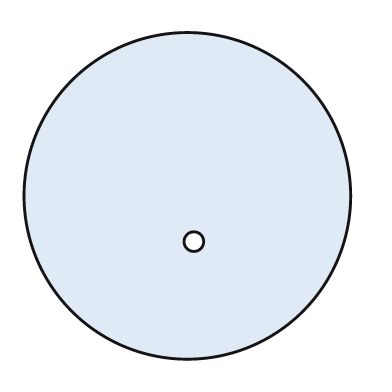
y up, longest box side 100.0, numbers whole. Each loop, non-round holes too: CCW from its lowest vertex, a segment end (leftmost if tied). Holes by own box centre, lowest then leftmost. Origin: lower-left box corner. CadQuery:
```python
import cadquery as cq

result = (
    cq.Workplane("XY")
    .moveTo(50.0, 50.0)
    .circle(50.0)
    .moveTo(52.0, 36.0)
    .circle(3.0)
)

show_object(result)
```